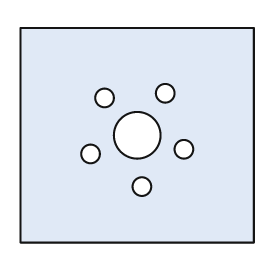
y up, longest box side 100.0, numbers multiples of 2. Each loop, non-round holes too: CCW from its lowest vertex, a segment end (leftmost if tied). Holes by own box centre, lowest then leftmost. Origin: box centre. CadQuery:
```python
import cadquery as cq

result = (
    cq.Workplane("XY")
    .moveTo(-50.0, -46.0)
    .lineTo(50.0, -46.0)
    .lineTo(50.0, 46.0)
    .lineTo(-50.0, 46.0)
    .close()
    .moveTo(2.0, -22.0)
    .circle(4.0)
    .moveTo(-20.0, -8.0)
    .circle(4.0)
    .moveTo(20.0, -6.0)
    .circle(4.0)
    .moveTo(0.0, 0.0)
    .circle(10.0)
    .moveTo(-14.0, 16.0)
    .circle(4.0)
    .moveTo(12.0, 18.0)
    .circle(4.0)
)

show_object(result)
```